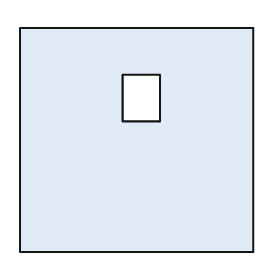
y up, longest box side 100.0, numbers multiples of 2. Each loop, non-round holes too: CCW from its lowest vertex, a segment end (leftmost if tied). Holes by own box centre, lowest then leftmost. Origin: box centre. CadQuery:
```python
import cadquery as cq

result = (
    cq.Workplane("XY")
    .moveTo(-50.0, -48.0)
    .lineTo(50.0, -48.0)
    .lineTo(50.0, 48.0)
    .lineTo(-50.0, 48.0)
    .close()
    .moveTo(-6.0, 8.0)
    .lineTo(10.0, 8.0)
    .lineTo(10.0, 28.0)
    .lineTo(-6.0, 28.0)
    .close()
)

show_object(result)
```